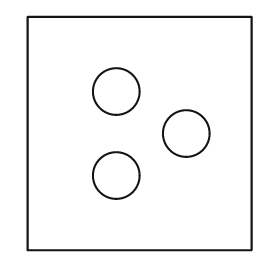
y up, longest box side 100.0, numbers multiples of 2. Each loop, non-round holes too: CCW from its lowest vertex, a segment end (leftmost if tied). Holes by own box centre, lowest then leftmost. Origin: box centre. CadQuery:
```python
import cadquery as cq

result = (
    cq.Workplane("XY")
    .moveTo(-48.0, -50.0)
    .lineTo(48.0, -50.0)
    .lineTo(48.0, 50.0)
    .lineTo(-48.0, 50.0)
    .close()
    .moveTo(-10.0, -18.0)
    .circle(10.0)
    .moveTo(20.0, 0.0)
    .circle(10.0)
    .moveTo(-10.0, 18.0)
    .circle(10.0)
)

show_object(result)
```